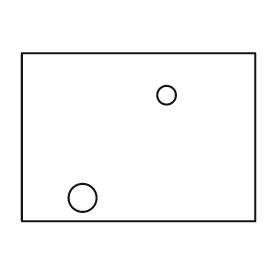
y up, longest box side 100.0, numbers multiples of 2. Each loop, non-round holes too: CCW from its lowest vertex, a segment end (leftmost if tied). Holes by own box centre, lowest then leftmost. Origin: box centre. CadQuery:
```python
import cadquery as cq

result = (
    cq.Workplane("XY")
    .moveTo(-50.0, -36.0)
    .lineTo(50.0, -36.0)
    .lineTo(50.0, 36.0)
    .lineTo(-50.0, 36.0)
    .close()
    .moveTo(-24.0, -26.0)
    .circle(6.0)
    .moveTo(12.0, 18.0)
    .circle(4.0)
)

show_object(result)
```